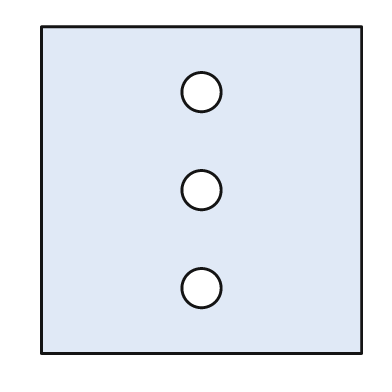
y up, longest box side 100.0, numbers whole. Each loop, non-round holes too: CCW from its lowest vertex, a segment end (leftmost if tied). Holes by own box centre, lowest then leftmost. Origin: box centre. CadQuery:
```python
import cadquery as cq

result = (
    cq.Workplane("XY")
    .moveTo(-49.0, -50.0)
    .lineTo(49.0, -50.0)
    .lineTo(49.0, 50.0)
    .lineTo(-49.0, 50.0)
    .close()
    .moveTo(0.0, -30.0)
    .circle(6.0)
    .moveTo(0.0, 0.0)
    .circle(6.0)
    .moveTo(0.0, 30.0)
    .circle(6.0)
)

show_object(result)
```